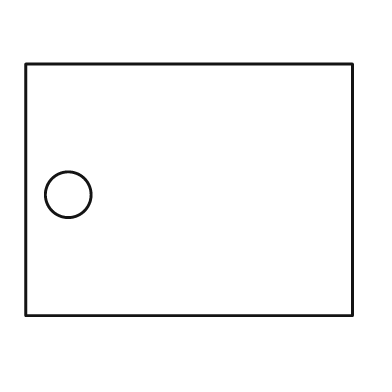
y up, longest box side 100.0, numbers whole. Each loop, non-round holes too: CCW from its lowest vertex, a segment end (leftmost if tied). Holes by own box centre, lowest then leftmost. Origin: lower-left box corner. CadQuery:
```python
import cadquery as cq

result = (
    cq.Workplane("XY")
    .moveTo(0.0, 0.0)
    .lineTo(100.0, 0.0)
    .lineTo(100.0, 77.0)
    .lineTo(0.0, 77.0)
    .close()
    .moveTo(13.0, 37.0)
    .circle(7.0)
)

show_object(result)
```